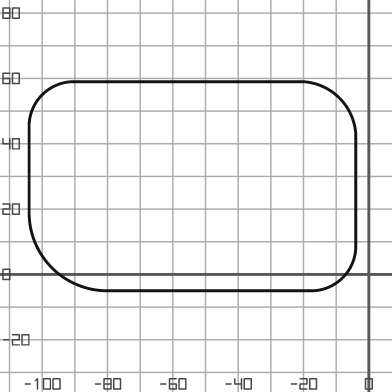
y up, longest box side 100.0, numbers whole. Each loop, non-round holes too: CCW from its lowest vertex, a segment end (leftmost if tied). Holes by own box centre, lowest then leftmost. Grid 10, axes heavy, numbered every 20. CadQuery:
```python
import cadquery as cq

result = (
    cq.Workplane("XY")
    .moveTo(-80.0, -5.0)
    .lineTo(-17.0, -5.0)
    .threePointArc((-8.0, -1.0), (-4.0, 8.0))
    .lineTo(-4.0, 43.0)
    .threePointArc((-9.0, 54.0), (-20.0, 59.0))
    .lineTo(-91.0, 59.0)
    .threePointArc((-100.0, 55.0), (-104.0, 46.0))
    .lineTo(-104.0, 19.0)
    .threePointArc((-97.0, 2.0), (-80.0, -5.0))
    .close()
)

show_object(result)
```